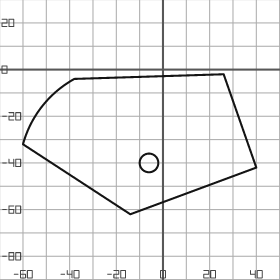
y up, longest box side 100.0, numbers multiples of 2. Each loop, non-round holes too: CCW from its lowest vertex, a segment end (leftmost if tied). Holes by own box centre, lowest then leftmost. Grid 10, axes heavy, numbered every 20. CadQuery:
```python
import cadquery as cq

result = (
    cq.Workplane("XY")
    .moveTo(-14.0, -62.0)
    .lineTo(40.0, -42.0)
    .lineTo(26.0, -2.0)
    .lineTo(-38.0, -4.0)
    .threePointArc((-52.0, -16.0), (-60.0, -32.0))
    .close()
    .moveTo(-6.0, -40.0)
    .circle(4.0)
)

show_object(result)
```